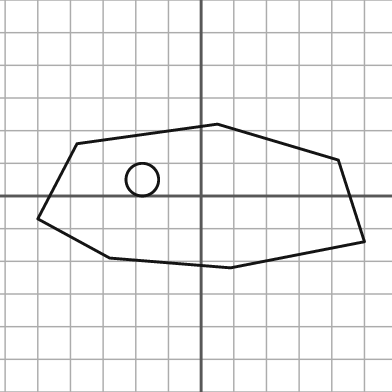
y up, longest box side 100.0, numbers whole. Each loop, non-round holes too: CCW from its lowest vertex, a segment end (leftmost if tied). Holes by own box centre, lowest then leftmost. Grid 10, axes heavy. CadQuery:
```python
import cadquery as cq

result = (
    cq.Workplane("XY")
    .moveTo(9.0, -22.0)
    .lineTo(50.0, -14.0)
    .lineTo(42.0, 11.0)
    .lineTo(5.0, 22.0)
    .lineTo(-38.0, 16.0)
    .lineTo(-50.0, -7.0)
    .lineTo(-28.0, -19.0)
    .close()
    .moveTo(-18.0, 5.0)
    .circle(5.0)
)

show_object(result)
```